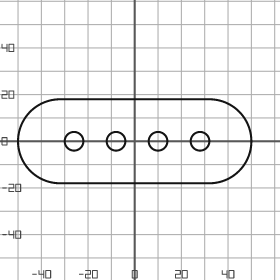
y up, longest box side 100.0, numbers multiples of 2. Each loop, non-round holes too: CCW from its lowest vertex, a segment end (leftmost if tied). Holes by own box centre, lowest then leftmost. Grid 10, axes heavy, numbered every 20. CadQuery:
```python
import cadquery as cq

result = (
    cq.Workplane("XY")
    .moveTo(-32.0, -18.0)
    .lineTo(32.0, -18.0)
    .threePointArc((50.0, 0.0), (32.0, 18.0))
    .lineTo(-32.0, 18.0)
    .threePointArc((-50.0, 0.0), (-32.0, -18.0))
    .close()
    .moveTo(-26.0, 0.0)
    .circle(4.0)
    .moveTo(-8.0, 0.0)
    .circle(4.0)
    .moveTo(10.0, 0.0)
    .circle(4.0)
    .moveTo(28.0, 0.0)
    .circle(4.0)
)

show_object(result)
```